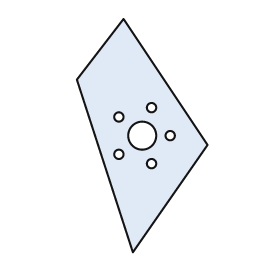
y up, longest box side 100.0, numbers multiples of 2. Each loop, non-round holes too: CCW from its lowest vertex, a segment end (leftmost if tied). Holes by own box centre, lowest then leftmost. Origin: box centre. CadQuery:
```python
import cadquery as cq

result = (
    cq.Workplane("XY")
    .moveTo(-4.0, -50.0)
    .lineTo(28.0, -4.0)
    .lineTo(-8.0, 50.0)
    .lineTo(-28.0, 24.0)
    .close()
    .moveTo(4.0, -12.0)
    .circle(2.0)
    .moveTo(-10.0, -8.0)
    .circle(2.0)
    .moveTo(0.0, 0.0)
    .circle(6.0)
    .moveTo(12.0, 0.0)
    .circle(2.0)
    .moveTo(-10.0, 8.0)
    .circle(2.0)
    .moveTo(4.0, 12.0)
    .circle(2.0)
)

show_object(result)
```